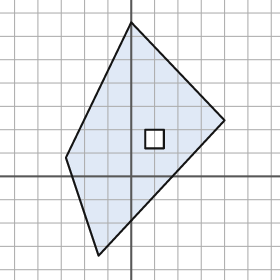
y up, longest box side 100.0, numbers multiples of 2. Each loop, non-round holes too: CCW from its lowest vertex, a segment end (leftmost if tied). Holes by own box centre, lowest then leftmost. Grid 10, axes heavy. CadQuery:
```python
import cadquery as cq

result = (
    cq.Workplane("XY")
    .moveTo(-14.0, -34.0)
    .lineTo(40.0, 24.0)
    .lineTo(0.0, 66.0)
    .lineTo(-28.0, 8.0)
    .close()
    .moveTo(6.0, 12.0)
    .lineTo(14.0, 12.0)
    .lineTo(14.0, 20.0)
    .lineTo(6.0, 20.0)
    .close()
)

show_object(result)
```